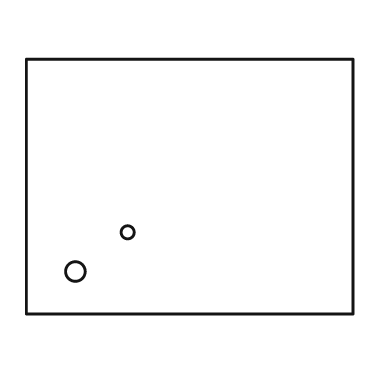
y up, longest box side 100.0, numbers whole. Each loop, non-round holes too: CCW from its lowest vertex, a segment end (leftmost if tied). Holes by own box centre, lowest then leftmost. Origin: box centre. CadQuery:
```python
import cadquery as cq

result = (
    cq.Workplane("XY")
    .moveTo(-50.0, -39.0)
    .lineTo(50.0, -39.0)
    .lineTo(50.0, 39.0)
    .lineTo(-50.0, 39.0)
    .close()
    .moveTo(-35.0, -26.0)
    .circle(3.0)
    .moveTo(-19.0, -14.0)
    .circle(2.0)
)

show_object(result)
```